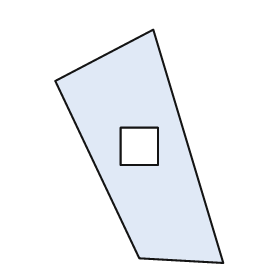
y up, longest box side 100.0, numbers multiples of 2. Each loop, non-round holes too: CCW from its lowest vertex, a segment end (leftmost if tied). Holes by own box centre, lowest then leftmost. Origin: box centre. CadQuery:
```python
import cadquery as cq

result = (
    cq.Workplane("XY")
    .moveTo(36.0, -50.0)
    .lineTo(6.0, 50.0)
    .lineTo(-36.0, 28.0)
    .lineTo(0.0, -48.0)
    .close()
    .moveTo(-8.0, -8.0)
    .lineTo(8.0, -8.0)
    .lineTo(8.0, 8.0)
    .lineTo(-8.0, 8.0)
    .close()
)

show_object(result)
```